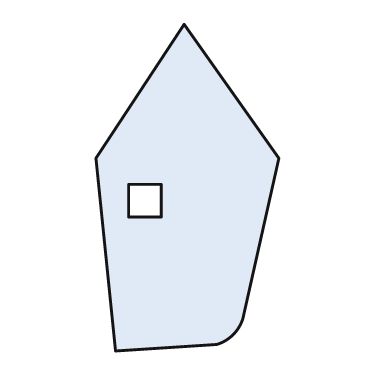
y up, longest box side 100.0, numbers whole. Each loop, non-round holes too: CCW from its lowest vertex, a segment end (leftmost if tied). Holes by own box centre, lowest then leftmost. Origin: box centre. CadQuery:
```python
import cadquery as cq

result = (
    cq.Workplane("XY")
    .moveTo(-22.0, -50.0)
    .lineTo(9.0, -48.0)
    .threePointArc((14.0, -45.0), (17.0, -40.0))
    .lineTo(28.0, 9.0)
    .lineTo(-1.0, 50.0)
    .lineTo(-28.0, 9.0)
    .close()
    .moveTo(-18.0, -9.0)
    .lineTo(-8.0, -9.0)
    .lineTo(-8.0, 1.0)
    .lineTo(-18.0, 1.0)
    .close()
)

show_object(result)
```